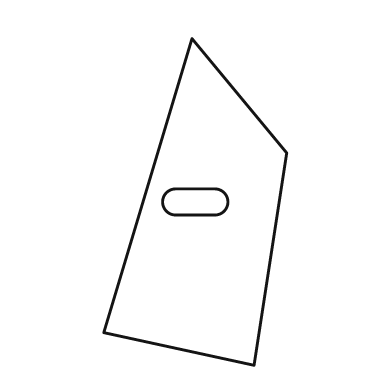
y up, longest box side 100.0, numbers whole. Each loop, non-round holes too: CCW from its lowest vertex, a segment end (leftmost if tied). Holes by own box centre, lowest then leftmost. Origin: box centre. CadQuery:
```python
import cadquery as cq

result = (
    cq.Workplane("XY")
    .moveTo(18.0, -50.0)
    .lineTo(28.0, 15.0)
    .lineTo(-1.0, 50.0)
    .lineTo(-28.0, -40.0)
    .close()
    .moveTo(-6.0, -4.0)
    .lineTo(6.0, -4.0)
    .threePointArc((10.0, 0.0), (6.0, 4.0))
    .lineTo(-6.0, 4.0)
    .threePointArc((-10.0, 0.0), (-6.0, -4.0))
    .close()
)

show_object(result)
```